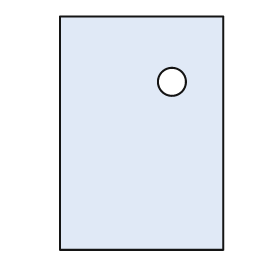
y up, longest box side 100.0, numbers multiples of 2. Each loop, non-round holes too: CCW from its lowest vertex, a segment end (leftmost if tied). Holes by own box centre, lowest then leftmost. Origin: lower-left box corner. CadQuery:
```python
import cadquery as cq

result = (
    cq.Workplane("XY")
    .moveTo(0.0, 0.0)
    .lineTo(70.0, 0.0)
    .lineTo(70.0, 100.0)
    .lineTo(0.0, 100.0)
    .close()
    .moveTo(48.0, 72.0)
    .circle(6.0)
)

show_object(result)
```